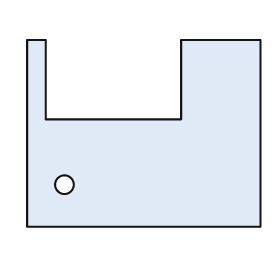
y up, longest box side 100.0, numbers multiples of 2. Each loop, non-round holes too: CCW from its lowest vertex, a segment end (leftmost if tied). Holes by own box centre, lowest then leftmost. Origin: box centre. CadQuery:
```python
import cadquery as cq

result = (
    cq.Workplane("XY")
    .moveTo(-50.0, -40.0)
    .lineTo(50.0, -40.0)
    .lineTo(50.0, 40.0)
    .lineTo(16.0, 40.0)
    .lineTo(16.0, 6.0)
    .lineTo(-42.0, 6.0)
    .lineTo(-42.0, 40.0)
    .lineTo(-50.0, 40.0)
    .close()
    .moveTo(-34.0, -22.0)
    .circle(4.0)
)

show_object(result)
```